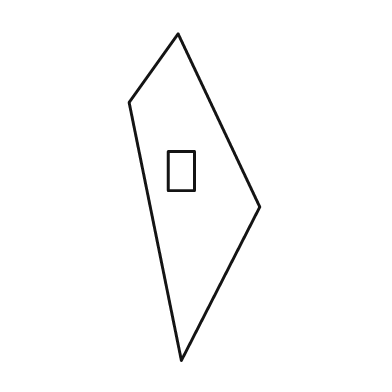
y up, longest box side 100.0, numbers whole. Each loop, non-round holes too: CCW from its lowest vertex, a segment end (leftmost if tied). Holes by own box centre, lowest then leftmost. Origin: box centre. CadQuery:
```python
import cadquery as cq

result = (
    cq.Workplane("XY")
    .moveTo(-4.0, -50.0)
    .lineTo(20.0, -3.0)
    .lineTo(-5.0, 50.0)
    .lineTo(-20.0, 29.0)
    .close()
    .moveTo(-8.0, 2.0)
    .lineTo(0.0, 2.0)
    .lineTo(0.0, 14.0)
    .lineTo(-8.0, 14.0)
    .close()
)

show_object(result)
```